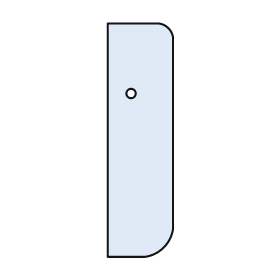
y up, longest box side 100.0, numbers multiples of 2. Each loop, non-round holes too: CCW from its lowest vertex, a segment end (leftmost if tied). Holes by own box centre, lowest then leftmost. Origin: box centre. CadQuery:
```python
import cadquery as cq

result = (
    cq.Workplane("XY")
    .moveTo(-14.0, -50.0)
    .lineTo(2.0, -50.0)
    .threePointArc((10.0, -46.0), (14.0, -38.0))
    .lineTo(14.0, 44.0)
    .threePointArc((12.0, 48.0), (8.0, 50.0))
    .lineTo(-14.0, 50.0)
    .close()
    .moveTo(-4.0, 20.0)
    .circle(2.0)
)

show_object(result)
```